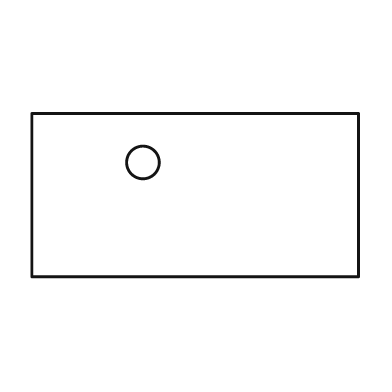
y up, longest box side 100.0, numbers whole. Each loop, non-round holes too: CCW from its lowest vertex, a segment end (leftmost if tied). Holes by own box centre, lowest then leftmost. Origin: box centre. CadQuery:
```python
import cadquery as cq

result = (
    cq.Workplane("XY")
    .moveTo(-50.0, -25.0)
    .lineTo(50.0, -25.0)
    .lineTo(50.0, 25.0)
    .lineTo(-50.0, 25.0)
    .close()
    .moveTo(-16.0, 10.0)
    .circle(5.0)
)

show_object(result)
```